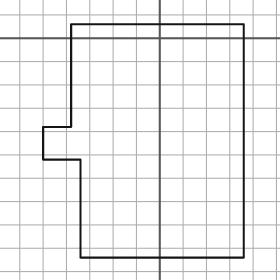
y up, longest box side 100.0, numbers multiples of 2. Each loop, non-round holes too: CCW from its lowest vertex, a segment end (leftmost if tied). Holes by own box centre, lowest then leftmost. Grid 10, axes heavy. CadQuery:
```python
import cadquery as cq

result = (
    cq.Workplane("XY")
    .moveTo(-34.0, -94.0)
    .lineTo(36.0, -94.0)
    .lineTo(36.0, 6.0)
    .lineTo(-38.0, 6.0)
    .lineTo(-38.0, -38.0)
    .lineTo(-50.0, -38.0)
    .lineTo(-50.0, -52.0)
    .lineTo(-34.0, -52.0)
    .close()
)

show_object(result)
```